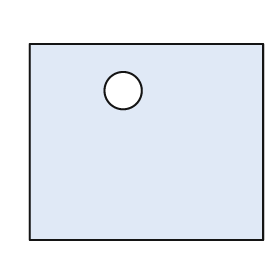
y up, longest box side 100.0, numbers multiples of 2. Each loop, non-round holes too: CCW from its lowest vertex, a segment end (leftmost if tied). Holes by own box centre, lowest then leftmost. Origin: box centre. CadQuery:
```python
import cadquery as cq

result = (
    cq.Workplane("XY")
    .moveTo(-50.0, -42.0)
    .lineTo(50.0, -42.0)
    .lineTo(50.0, 42.0)
    .lineTo(-50.0, 42.0)
    .close()
    .moveTo(-10.0, 22.0)
    .circle(8.0)
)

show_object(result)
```